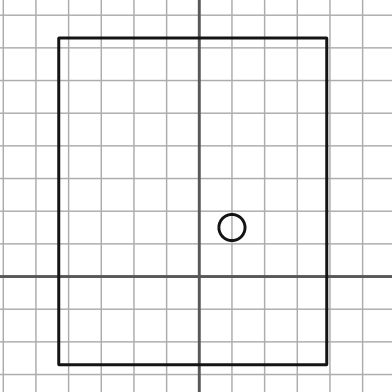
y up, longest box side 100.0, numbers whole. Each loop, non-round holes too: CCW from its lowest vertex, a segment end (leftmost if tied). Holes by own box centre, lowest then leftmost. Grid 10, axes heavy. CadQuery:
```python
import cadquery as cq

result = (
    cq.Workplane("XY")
    .moveTo(-43.0, -27.0)
    .lineTo(39.0, -27.0)
    .lineTo(39.0, 73.0)
    .lineTo(-43.0, 73.0)
    .close()
    .moveTo(10.0, 15.0)
    .circle(4.0)
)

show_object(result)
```